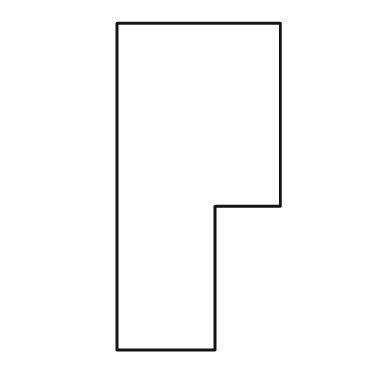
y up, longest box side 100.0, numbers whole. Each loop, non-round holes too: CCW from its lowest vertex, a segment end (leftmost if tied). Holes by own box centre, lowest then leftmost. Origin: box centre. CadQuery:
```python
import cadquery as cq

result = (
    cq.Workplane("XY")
    .moveTo(-25.0, -50.0)
    .lineTo(5.0, -50.0)
    .lineTo(5.0, -6.0)
    .lineTo(25.0, -6.0)
    .lineTo(25.0, 50.0)
    .lineTo(-25.0, 50.0)
    .close()
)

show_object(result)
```